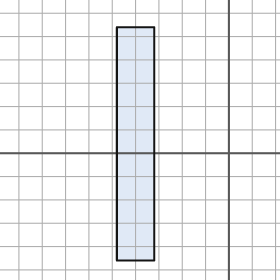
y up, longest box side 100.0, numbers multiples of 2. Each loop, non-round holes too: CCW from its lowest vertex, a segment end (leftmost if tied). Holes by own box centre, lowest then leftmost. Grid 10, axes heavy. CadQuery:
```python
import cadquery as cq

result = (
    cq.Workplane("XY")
    .moveTo(-48.0, -46.0)
    .lineTo(-32.0, -46.0)
    .lineTo(-32.0, 54.0)
    .lineTo(-48.0, 54.0)
    .close()
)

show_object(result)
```